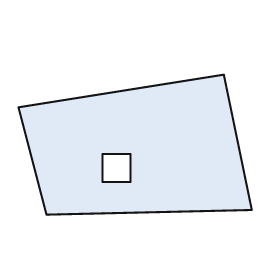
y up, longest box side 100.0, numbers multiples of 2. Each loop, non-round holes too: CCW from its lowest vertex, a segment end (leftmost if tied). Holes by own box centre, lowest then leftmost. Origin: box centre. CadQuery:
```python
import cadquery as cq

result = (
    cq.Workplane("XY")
    .moveTo(-38.0, -30.0)
    .lineTo(50.0, -28.0)
    .lineTo(38.0, 30.0)
    .lineTo(-50.0, 16.0)
    .close()
    .moveTo(-14.0, -16.0)
    .lineTo(-2.0, -16.0)
    .lineTo(-2.0, -4.0)
    .lineTo(-14.0, -4.0)
    .close()
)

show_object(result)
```